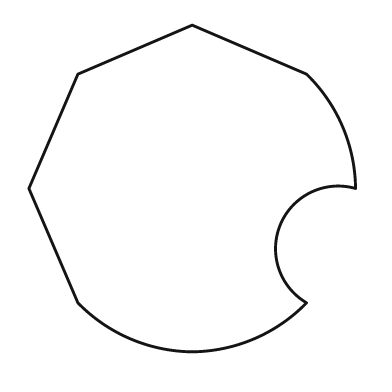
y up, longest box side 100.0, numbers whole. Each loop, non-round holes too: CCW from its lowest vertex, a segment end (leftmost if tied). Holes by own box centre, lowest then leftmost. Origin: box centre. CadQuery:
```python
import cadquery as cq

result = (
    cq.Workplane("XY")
    .moveTo(0.0, -50.0)
    .threePointArc((19.0, -46.0), (35.0, -35.0))
    .threePointArc((27.0, -11.0), (50.0, 0.0))
    .threePointArc((46.0, 19.0), (35.0, 35.0))
    .lineTo(0.0, 50.0)
    .lineTo(-35.0, 35.0)
    .lineTo(-50.0, 0.0)
    .lineTo(-35.0, -35.0)
    .threePointArc((-19.0, -46.0), (0.0, -50.0))
    .close()
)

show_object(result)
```